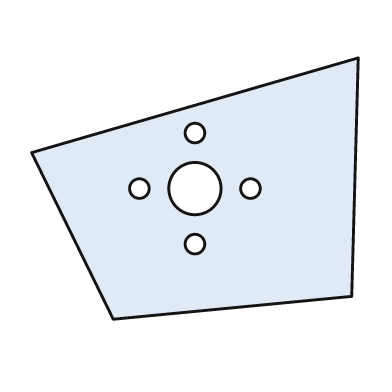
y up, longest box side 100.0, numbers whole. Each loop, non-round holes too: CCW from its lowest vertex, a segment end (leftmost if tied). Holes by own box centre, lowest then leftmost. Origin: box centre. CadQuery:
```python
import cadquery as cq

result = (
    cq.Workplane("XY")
    .moveTo(-25.0, -40.0)
    .lineTo(48.0, -33.0)
    .lineTo(50.0, 40.0)
    .lineTo(-50.0, 11.0)
    .close()
    .moveTo(0.0, -17.0)
    .circle(3.0)
    .moveTo(-17.0, 0.0)
    .circle(3.0)
    .moveTo(0.0, 0.0)
    .circle(8.0)
    .moveTo(17.0, 0.0)
    .circle(3.0)
    .moveTo(0.0, 17.0)
    .circle(3.0)
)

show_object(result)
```